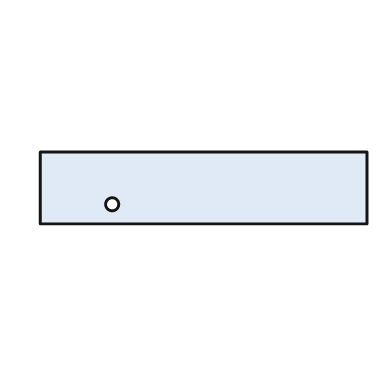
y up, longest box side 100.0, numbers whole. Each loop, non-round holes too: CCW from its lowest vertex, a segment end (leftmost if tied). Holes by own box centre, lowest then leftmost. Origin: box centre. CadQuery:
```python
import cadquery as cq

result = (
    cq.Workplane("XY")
    .moveTo(-50.0, -11.0)
    .lineTo(50.0, -11.0)
    .lineTo(50.0, 11.0)
    .lineTo(-50.0, 11.0)
    .close()
    .moveTo(-28.0, -5.0)
    .circle(2.0)
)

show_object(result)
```